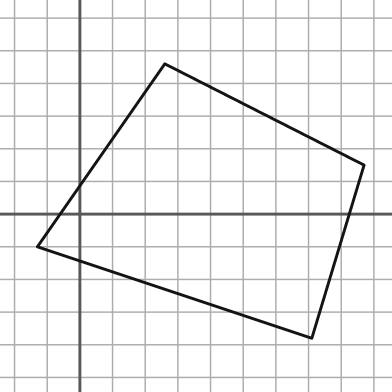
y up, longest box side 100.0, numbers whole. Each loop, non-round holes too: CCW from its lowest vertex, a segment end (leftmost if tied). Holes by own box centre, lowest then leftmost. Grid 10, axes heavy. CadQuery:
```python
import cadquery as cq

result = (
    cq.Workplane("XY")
    .moveTo(71.0, -38.0)
    .lineTo(87.0, 15.0)
    .lineTo(26.0, 46.0)
    .lineTo(-13.0, -10.0)
    .close()
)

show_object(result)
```